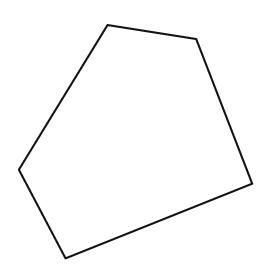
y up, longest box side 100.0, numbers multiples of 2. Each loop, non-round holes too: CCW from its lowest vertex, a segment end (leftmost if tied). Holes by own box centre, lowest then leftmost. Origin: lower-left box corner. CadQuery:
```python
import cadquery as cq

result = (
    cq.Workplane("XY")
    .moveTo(20.0, 0.0)
    .lineTo(100.0, 32.0)
    .lineTo(76.0, 94.0)
    .lineTo(38.0, 100.0)
    .lineTo(0.0, 38.0)
    .close()
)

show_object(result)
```